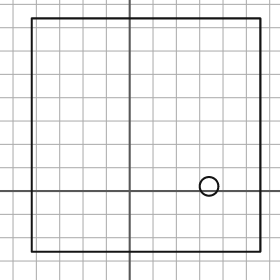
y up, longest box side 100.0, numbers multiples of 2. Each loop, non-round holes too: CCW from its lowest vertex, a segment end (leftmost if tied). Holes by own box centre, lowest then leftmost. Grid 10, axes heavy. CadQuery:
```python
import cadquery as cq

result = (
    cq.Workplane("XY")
    .moveTo(-42.0, -26.0)
    .lineTo(56.0, -26.0)
    .lineTo(56.0, 74.0)
    .lineTo(-42.0, 74.0)
    .close()
    .moveTo(34.0, 2.0)
    .circle(4.0)
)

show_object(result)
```